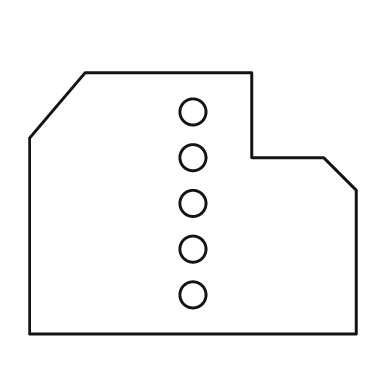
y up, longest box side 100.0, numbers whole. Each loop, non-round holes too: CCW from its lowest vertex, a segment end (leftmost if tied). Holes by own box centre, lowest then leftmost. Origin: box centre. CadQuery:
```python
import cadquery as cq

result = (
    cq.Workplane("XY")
    .moveTo(-50.0, -40.0)
    .lineTo(50.0, -40.0)
    .lineTo(50.0, 4.0)
    .lineTo(40.0, 14.0)
    .lineTo(18.0, 14.0)
    .lineTo(18.0, 40.0)
    .lineTo(-33.0, 40.0)
    .lineTo(-50.0, 20.0)
    .close()
    .moveTo(0.0, -28.0)
    .circle(4.0)
    .moveTo(0.0, -14.0)
    .circle(4.0)
    .moveTo(0.0, 0.0)
    .circle(4.0)
    .moveTo(0.0, 14.0)
    .circle(4.0)
    .moveTo(0.0, 28.0)
    .circle(4.0)
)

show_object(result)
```